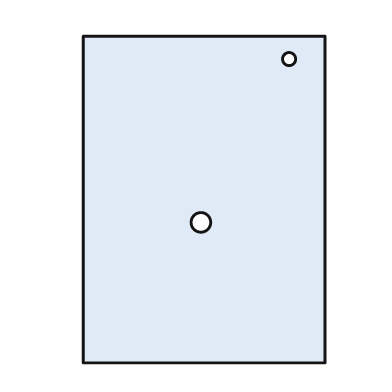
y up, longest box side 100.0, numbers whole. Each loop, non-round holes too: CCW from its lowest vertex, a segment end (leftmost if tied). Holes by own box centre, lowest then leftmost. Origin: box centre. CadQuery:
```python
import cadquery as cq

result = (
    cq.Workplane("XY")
    .moveTo(-37.0, -50.0)
    .lineTo(37.0, -50.0)
    .lineTo(37.0, 50.0)
    .lineTo(-37.0, 50.0)
    .close()
    .moveTo(-1.0, -7.0)
    .circle(3.0)
    .moveTo(26.0, 43.0)
    .circle(2.0)
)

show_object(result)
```